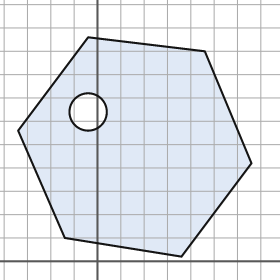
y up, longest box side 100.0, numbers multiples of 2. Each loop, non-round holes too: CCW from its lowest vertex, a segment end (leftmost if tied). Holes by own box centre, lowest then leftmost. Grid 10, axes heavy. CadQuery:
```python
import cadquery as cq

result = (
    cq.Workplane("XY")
    .moveTo(36.0, 2.0)
    .lineTo(66.0, 42.0)
    .lineTo(46.0, 90.0)
    .lineTo(-4.0, 96.0)
    .lineTo(-34.0, 56.0)
    .lineTo(-14.0, 10.0)
    .close()
    .moveTo(-4.0, 64.0)
    .circle(8.0)
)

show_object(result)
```